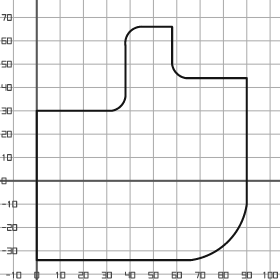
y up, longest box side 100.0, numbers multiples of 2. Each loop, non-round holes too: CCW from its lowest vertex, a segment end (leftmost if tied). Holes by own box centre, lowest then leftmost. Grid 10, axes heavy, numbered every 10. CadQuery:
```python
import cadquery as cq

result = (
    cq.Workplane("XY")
    .moveTo(0.0, -34.0)
    .lineTo(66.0, -34.0)
    .threePointArc((82.0, -26.0), (90.0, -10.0))
    .lineTo(90.0, 44.0)
    .lineTo(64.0, 44.0)
    .threePointArc((60.0, 46.0), (58.0, 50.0))
    .lineTo(58.0, 66.0)
    .lineTo(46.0, 66.0)
    .threePointArc((40.0, 64.0), (38.0, 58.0))
    .lineTo(38.0, 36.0)
    .threePointArc((36.0, 32.0), (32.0, 30.0))
    .lineTo(0.0, 30.0)
    .close()
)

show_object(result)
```